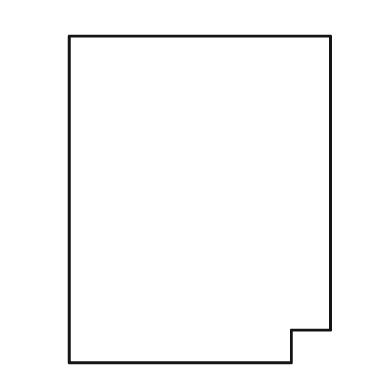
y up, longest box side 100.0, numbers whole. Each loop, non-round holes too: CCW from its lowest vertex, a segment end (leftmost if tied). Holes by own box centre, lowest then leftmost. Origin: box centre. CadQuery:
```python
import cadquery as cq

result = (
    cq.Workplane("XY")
    .moveTo(-40.0, -50.0)
    .lineTo(28.0, -50.0)
    .lineTo(28.0, -40.0)
    .lineTo(40.0, -40.0)
    .lineTo(40.0, 50.0)
    .lineTo(-40.0, 50.0)
    .close()
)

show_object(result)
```